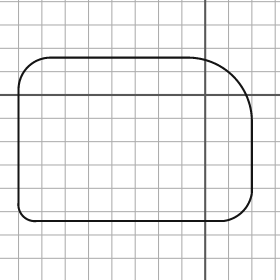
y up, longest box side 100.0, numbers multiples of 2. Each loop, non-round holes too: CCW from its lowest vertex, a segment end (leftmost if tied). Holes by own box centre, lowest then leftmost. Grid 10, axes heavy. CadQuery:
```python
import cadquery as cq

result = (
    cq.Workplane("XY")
    .moveTo(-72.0, -54.0)
    .lineTo(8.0, -54.0)
    .threePointArc((16.0, -50.0), (20.0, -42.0))
    .lineTo(20.0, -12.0)
    .threePointArc((12.0, 8.0), (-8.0, 16.0))
    .lineTo(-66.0, 16.0)
    .threePointArc((-76.0, 12.0), (-80.0, 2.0))
    .lineTo(-80.0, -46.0)
    .threePointArc((-78.0, -52.0), (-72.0, -54.0))
    .close()
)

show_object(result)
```